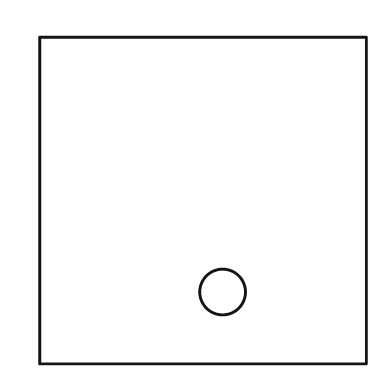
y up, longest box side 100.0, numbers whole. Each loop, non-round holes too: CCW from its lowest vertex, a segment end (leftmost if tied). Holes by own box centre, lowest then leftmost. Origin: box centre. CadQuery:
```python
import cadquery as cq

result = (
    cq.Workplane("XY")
    .moveTo(-50.0, -50.0)
    .lineTo(50.0, -50.0)
    .lineTo(50.0, 50.0)
    .lineTo(-50.0, 50.0)
    .close()
    .moveTo(6.0, -28.0)
    .circle(7.0)
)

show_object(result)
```